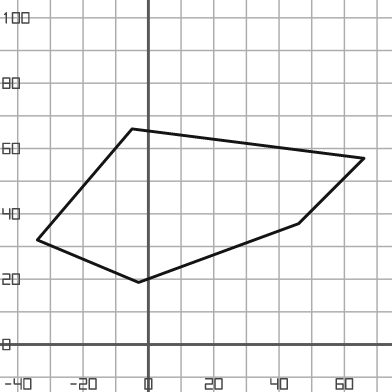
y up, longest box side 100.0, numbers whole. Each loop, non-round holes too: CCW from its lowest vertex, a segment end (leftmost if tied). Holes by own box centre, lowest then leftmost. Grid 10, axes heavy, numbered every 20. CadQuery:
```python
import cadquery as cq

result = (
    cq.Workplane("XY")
    .moveTo(-3.0, 19.0)
    .lineTo(46.0, 37.0)
    .lineTo(66.0, 57.0)
    .lineTo(-5.0, 66.0)
    .lineTo(-34.0, 32.0)
    .close()
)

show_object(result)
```